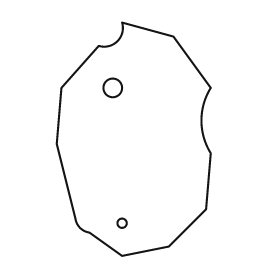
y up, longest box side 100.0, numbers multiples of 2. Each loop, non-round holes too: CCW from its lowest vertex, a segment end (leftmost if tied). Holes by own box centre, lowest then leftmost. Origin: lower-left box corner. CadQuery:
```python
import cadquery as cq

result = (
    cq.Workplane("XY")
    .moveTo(28.0, 0.0)
    .lineTo(48.0, 4.0)
    .lineTo(64.0, 20.0)
    .lineTo(66.0, 44.0)
    .threePointArc((62.0, 58.0), (66.0, 72.0))
    .lineTo(50.0, 94.0)
    .lineTo(28.0, 100.0)
    .threePointArc((26.0, 92.0), (18.0, 90.0))
    .lineTo(2.0, 72.0)
    .lineTo(0.0, 48.0)
    .lineTo(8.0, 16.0)
    .threePointArc((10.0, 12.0), (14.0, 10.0))
    .close()
    .moveTo(28.0, 14.0)
    .circle(2.0)
    .moveTo(24.0, 72.0)
    .circle(4.0)
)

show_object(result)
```